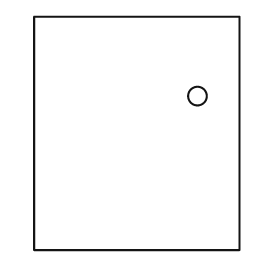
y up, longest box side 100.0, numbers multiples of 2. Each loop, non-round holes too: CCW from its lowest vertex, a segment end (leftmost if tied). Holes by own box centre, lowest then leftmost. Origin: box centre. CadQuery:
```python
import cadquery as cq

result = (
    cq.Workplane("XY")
    .moveTo(-44.0, -50.0)
    .lineTo(44.0, -50.0)
    .lineTo(44.0, 50.0)
    .lineTo(-44.0, 50.0)
    .close()
    .moveTo(26.0, 16.0)
    .circle(4.0)
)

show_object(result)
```